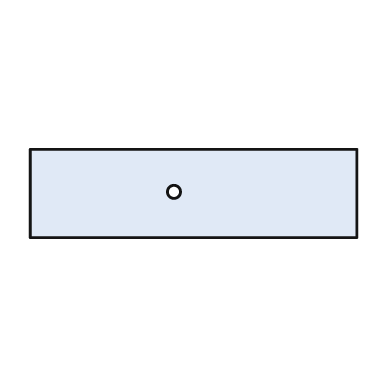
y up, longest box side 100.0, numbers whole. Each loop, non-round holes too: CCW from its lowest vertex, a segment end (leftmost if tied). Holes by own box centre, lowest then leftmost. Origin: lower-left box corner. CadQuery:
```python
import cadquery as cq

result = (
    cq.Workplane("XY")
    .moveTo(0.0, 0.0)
    .lineTo(100.0, 0.0)
    .lineTo(100.0, 27.0)
    .lineTo(0.0, 27.0)
    .close()
    .moveTo(44.0, 14.0)
    .circle(2.0)
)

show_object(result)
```